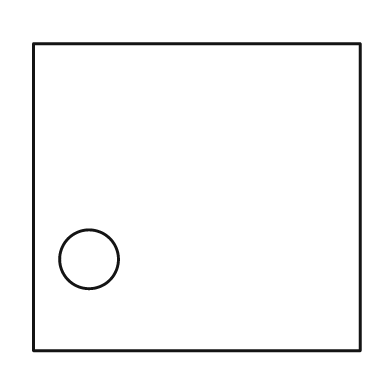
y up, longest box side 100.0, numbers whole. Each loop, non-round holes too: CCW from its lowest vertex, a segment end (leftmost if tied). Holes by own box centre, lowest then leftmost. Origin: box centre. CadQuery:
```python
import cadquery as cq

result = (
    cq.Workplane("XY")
    .moveTo(-50.0, -47.0)
    .lineTo(50.0, -47.0)
    .lineTo(50.0, 47.0)
    .lineTo(-50.0, 47.0)
    .close()
    .moveTo(-33.0, -19.0)
    .circle(9.0)
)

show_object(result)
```